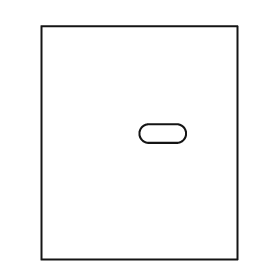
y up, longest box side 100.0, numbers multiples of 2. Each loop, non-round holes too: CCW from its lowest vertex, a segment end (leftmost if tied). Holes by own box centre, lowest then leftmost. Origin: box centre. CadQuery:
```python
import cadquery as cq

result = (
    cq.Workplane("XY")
    .moveTo(-42.0, -50.0)
    .lineTo(42.0, -50.0)
    .lineTo(42.0, 50.0)
    .lineTo(-42.0, 50.0)
    .close()
    .moveTo(4.0, 0.0)
    .lineTo(16.0, 0.0)
    .threePointArc((20.0, 4.0), (16.0, 8.0))
    .lineTo(4.0, 8.0)
    .threePointArc((0.0, 4.0), (4.0, 0.0))
    .close()
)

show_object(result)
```